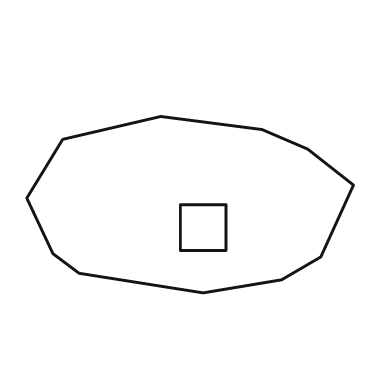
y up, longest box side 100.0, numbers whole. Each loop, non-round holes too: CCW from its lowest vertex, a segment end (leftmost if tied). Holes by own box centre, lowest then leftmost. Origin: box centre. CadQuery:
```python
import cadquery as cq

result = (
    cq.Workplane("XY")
    .moveTo(4.0, -27.0)
    .lineTo(28.0, -23.0)
    .lineTo(40.0, -16.0)
    .lineTo(50.0, 6.0)
    .lineTo(36.0, 17.0)
    .lineTo(22.0, 23.0)
    .lineTo(-9.0, 27.0)
    .lineTo(-39.0, 20.0)
    .lineTo(-50.0, 2.0)
    .lineTo(-42.0, -15.0)
    .lineTo(-34.0, -21.0)
    .close()
    .moveTo(-3.0, -14.0)
    .lineTo(11.0, -14.0)
    .lineTo(11.0, 0.0)
    .lineTo(-3.0, 0.0)
    .close()
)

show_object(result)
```